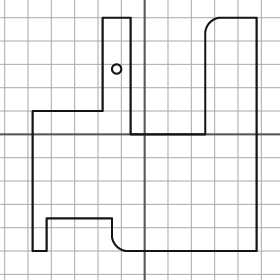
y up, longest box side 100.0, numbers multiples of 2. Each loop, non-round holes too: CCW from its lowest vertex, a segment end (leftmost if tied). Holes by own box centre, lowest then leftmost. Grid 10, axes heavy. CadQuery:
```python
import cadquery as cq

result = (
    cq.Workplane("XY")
    .moveTo(-48.0, -50.0)
    .lineTo(-42.0, -50.0)
    .lineTo(-42.0, -36.0)
    .lineTo(-14.0, -36.0)
    .lineTo(-14.0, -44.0)
    .threePointArc((-12.0, -48.0), (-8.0, -50.0))
    .lineTo(48.0, -50.0)
    .lineTo(48.0, 50.0)
    .lineTo(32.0, 50.0)
    .threePointArc((28.0, 48.0), (26.0, 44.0))
    .lineTo(26.0, 0.0)
    .lineTo(-6.0, 0.0)
    .lineTo(-6.0, 50.0)
    .lineTo(-18.0, 50.0)
    .lineTo(-18.0, 10.0)
    .lineTo(-48.0, 10.0)
    .close()
    .moveTo(-12.0, 28.0)
    .circle(2.0)
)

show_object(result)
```